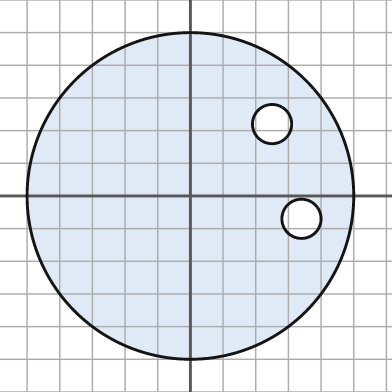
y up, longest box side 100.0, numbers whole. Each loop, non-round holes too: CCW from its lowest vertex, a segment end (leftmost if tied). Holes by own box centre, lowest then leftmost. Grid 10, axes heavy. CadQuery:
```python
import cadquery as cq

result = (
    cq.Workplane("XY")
    .moveTo(0.0, 0.0)
    .circle(50.0)
    .moveTo(34.0, -7.0)
    .circle(6.0)
    .moveTo(25.0, 22.0)
    .circle(6.0)
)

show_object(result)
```